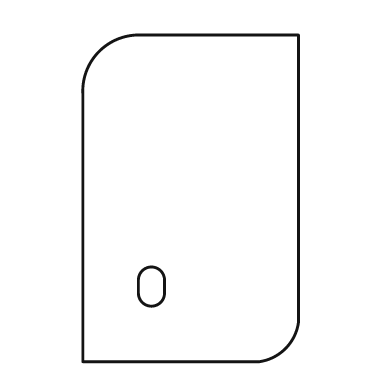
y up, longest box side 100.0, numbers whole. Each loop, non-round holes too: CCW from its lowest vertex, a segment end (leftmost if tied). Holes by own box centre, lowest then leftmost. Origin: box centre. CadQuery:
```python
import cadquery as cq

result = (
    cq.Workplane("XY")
    .moveTo(-33.0, -50.0)
    .lineTo(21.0, -50.0)
    .threePointArc((29.0, -46.0), (33.0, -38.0))
    .lineTo(33.0, 50.0)
    .lineTo(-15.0, 50.0)
    .threePointArc((-28.0, 45.0), (-33.0, 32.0))
    .close()
    .moveTo(-16.0, -29.0)
    .threePointArc((-12.0, -33.0), (-8.0, -29.0))
    .lineTo(-8.0, -25.0)
    .threePointArc((-12.0, -21.0), (-16.0, -25.0))
    .close()
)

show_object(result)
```